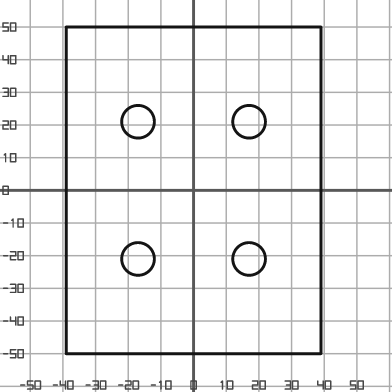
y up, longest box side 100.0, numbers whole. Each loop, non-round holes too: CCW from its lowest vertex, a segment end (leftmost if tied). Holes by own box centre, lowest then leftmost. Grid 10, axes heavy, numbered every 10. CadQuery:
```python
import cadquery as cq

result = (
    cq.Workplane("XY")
    .moveTo(-39.0, -50.0)
    .lineTo(39.0, -50.0)
    .lineTo(39.0, 50.0)
    .lineTo(-39.0, 50.0)
    .close()
    .moveTo(-17.0, -21.0)
    .circle(5.0)
    .moveTo(17.0, -21.0)
    .circle(5.0)
    .moveTo(-17.0, 21.0)
    .circle(5.0)
    .moveTo(17.0, 21.0)
    .circle(5.0)
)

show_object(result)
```